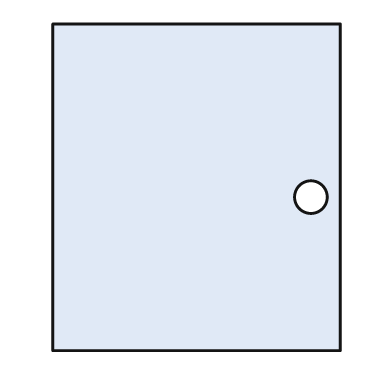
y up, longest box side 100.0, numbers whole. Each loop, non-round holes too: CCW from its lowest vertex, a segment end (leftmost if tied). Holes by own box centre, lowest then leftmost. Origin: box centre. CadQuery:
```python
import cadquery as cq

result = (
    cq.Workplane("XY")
    .moveTo(-44.0, -50.0)
    .lineTo(44.0, -50.0)
    .lineTo(44.0, 50.0)
    .lineTo(-44.0, 50.0)
    .close()
    .moveTo(35.0, -3.0)
    .circle(5.0)
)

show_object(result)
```